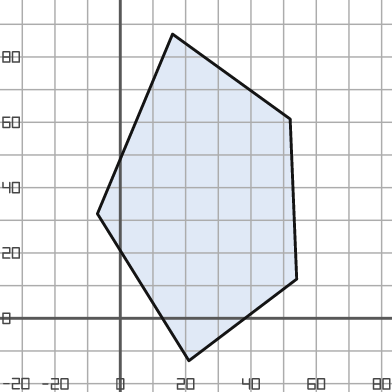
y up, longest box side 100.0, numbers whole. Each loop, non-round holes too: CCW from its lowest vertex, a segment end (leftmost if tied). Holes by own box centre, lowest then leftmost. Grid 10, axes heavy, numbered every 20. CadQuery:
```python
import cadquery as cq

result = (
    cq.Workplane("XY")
    .moveTo(21.0, -13.0)
    .lineTo(54.0, 12.0)
    .lineTo(52.0, 61.0)
    .lineTo(16.0, 87.0)
    .lineTo(-7.0, 32.0)
    .close()
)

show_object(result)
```